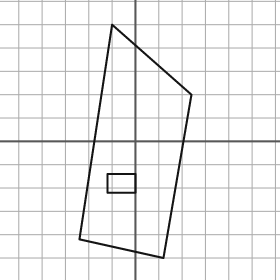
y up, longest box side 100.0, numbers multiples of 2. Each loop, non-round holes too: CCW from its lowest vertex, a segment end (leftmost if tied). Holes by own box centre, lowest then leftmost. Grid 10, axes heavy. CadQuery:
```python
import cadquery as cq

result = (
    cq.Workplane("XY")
    .moveTo(12.0, -50.0)
    .lineTo(24.0, 20.0)
    .lineTo(-10.0, 50.0)
    .lineTo(-24.0, -42.0)
    .close()
    .moveTo(-12.0, -22.0)
    .lineTo(0.0, -22.0)
    .lineTo(0.0, -14.0)
    .lineTo(-12.0, -14.0)
    .close()
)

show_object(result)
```